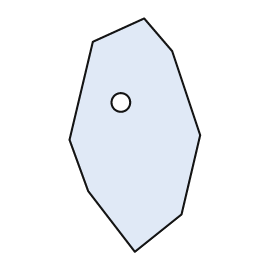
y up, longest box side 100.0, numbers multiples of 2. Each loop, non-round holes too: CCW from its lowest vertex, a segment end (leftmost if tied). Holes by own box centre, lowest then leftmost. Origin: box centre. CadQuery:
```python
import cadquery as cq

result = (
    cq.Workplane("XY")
    .moveTo(0.0, -50.0)
    .lineTo(20.0, -34.0)
    .lineTo(28.0, 0.0)
    .lineTo(16.0, 36.0)
    .lineTo(4.0, 50.0)
    .lineTo(-18.0, 40.0)
    .lineTo(-28.0, -2.0)
    .lineTo(-20.0, -24.0)
    .close()
    .moveTo(-6.0, 14.0)
    .circle(4.0)
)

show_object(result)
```